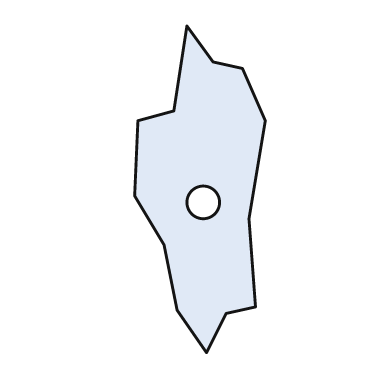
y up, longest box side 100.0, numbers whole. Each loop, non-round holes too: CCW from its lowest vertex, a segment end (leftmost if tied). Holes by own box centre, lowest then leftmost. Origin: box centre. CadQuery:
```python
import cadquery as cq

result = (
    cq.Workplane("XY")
    .moveTo(2.0, -50.0)
    .lineTo(8.0, -38.0)
    .lineTo(17.0, -36.0)
    .lineTo(15.0, -9.0)
    .lineTo(20.0, 21.0)
    .lineTo(13.0, 37.0)
    .lineTo(4.0, 39.0)
    .lineTo(-4.0, 50.0)
    .lineTo(-8.0, 24.0)
    .lineTo(-19.0, 21.0)
    .lineTo(-20.0, -2.0)
    .lineTo(-11.0, -17.0)
    .lineTo(-7.0, -37.0)
    .close()
    .moveTo(1.0, -4.0)
    .circle(5.0)
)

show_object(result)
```